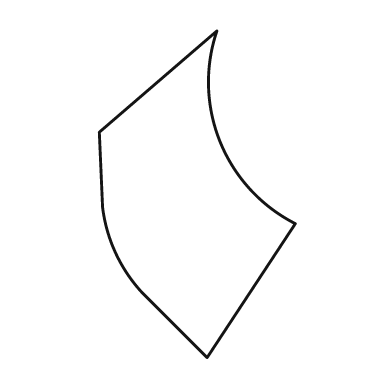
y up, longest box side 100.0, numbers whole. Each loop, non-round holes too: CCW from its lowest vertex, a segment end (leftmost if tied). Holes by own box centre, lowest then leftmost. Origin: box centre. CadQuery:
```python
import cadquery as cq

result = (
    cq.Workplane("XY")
    .moveTo(3.0, -50.0)
    .lineTo(30.0, -9.0)
    .threePointArc((7.0, 16.0), (6.0, 50.0))
    .lineTo(-30.0, 19.0)
    .lineTo(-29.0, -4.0)
    .threePointArc((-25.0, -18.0), (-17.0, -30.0))
    .close()
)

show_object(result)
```